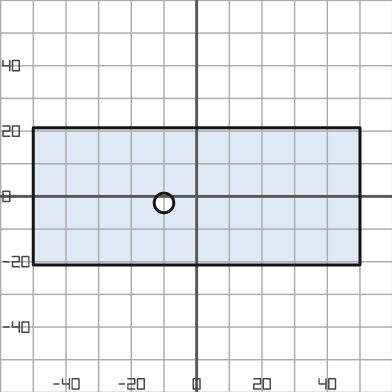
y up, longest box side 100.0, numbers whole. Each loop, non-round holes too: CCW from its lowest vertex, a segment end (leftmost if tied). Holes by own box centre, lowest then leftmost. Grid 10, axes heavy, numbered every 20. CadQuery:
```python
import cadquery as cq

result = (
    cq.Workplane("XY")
    .moveTo(-50.0, -21.0)
    .lineTo(50.0, -21.0)
    .lineTo(50.0, 21.0)
    .lineTo(-50.0, 21.0)
    .close()
    .moveTo(-10.0, -2.0)
    .circle(3.0)
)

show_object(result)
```